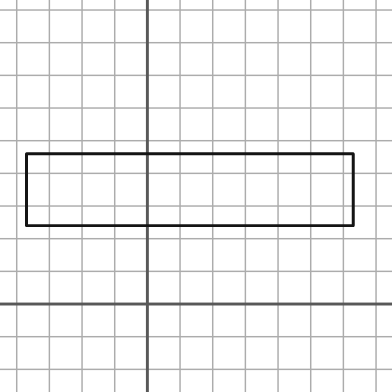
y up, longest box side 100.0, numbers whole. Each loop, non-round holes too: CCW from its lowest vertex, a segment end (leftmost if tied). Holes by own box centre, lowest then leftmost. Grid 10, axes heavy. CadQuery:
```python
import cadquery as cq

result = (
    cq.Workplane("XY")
    .moveTo(-37.0, 24.0)
    .lineTo(63.0, 24.0)
    .lineTo(63.0, 46.0)
    .lineTo(-37.0, 46.0)
    .close()
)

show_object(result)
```